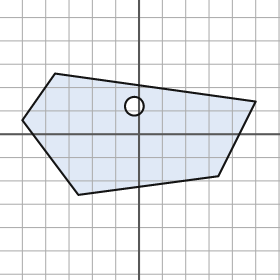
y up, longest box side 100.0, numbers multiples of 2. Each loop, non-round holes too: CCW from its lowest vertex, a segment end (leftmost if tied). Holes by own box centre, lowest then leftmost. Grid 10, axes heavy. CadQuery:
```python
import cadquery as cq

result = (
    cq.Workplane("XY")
    .moveTo(-26.0, -26.0)
    .lineTo(34.0, -18.0)
    .lineTo(50.0, 14.0)
    .lineTo(-36.0, 26.0)
    .lineTo(-50.0, 6.0)
    .close()
    .moveTo(-2.0, 12.0)
    .circle(4.0)
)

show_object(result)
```